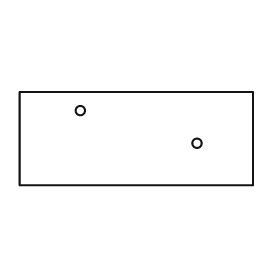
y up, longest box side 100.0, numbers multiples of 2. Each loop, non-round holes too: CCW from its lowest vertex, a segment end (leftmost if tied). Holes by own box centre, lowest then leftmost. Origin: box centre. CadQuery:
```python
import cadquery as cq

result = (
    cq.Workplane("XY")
    .moveTo(-50.0, -20.0)
    .lineTo(50.0, -20.0)
    .lineTo(50.0, 20.0)
    .lineTo(-50.0, 20.0)
    .close()
    .moveTo(26.0, -2.0)
    .circle(2.0)
    .moveTo(-24.0, 12.0)
    .circle(2.0)
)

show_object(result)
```